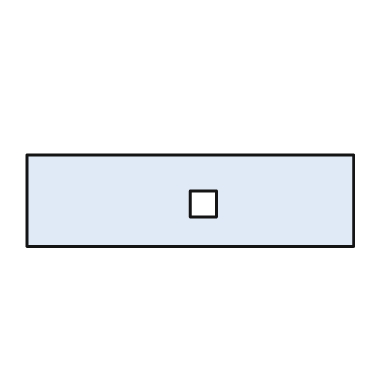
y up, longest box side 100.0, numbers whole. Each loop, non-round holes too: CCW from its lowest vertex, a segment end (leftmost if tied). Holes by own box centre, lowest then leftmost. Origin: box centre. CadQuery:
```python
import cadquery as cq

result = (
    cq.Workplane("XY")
    .moveTo(-50.0, -14.0)
    .lineTo(50.0, -14.0)
    .lineTo(50.0, 14.0)
    .lineTo(-50.0, 14.0)
    .close()
    .moveTo(0.0, -5.0)
    .lineTo(8.0, -5.0)
    .lineTo(8.0, 3.0)
    .lineTo(0.0, 3.0)
    .close()
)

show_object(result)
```